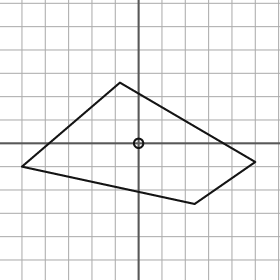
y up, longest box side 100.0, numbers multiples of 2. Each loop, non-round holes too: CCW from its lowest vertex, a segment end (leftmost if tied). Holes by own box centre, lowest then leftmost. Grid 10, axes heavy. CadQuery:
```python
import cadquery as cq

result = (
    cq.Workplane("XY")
    .moveTo(24.0, -26.0)
    .lineTo(50.0, -8.0)
    .lineTo(-8.0, 26.0)
    .lineTo(-50.0, -10.0)
    .close()
    .moveTo(0.0, 0.0)
    .circle(2.0)
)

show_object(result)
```